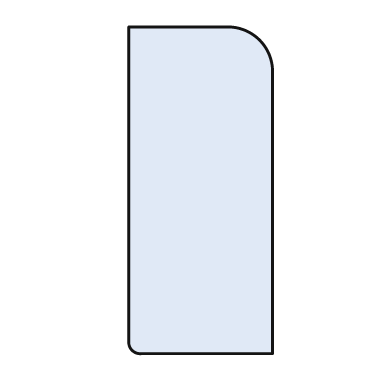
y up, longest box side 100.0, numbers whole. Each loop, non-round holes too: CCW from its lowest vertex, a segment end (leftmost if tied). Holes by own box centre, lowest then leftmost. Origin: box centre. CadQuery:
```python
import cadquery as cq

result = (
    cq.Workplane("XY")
    .moveTo(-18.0, -50.0)
    .lineTo(22.0, -50.0)
    .lineTo(22.0, 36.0)
    .threePointArc((18.0, 46.0), (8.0, 50.0))
    .lineTo(-22.0, 50.0)
    .lineTo(-22.0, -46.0)
    .threePointArc((-21.0, -49.0), (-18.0, -50.0))
    .close()
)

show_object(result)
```